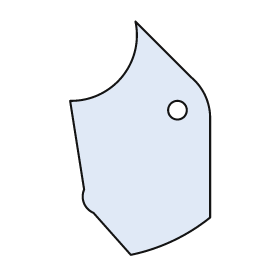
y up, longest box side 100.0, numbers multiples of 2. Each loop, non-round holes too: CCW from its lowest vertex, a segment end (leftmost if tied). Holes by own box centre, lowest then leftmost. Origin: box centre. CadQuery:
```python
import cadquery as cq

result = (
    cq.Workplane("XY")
    .moveTo(-4.0, -50.0)
    .threePointArc((14.0, -44.0), (30.0, -34.0))
    .lineTo(30.0, 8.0)
    .threePointArc((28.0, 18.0), (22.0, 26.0))
    .lineTo(-2.0, 50.0)
    .threePointArc((-8.0, 26.0), (-30.0, 16.0))
    .lineTo(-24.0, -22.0)
    .threePointArc((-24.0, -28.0), (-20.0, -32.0))
    .close()
    .moveTo(16.0, 12.0)
    .circle(4.0)
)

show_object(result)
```